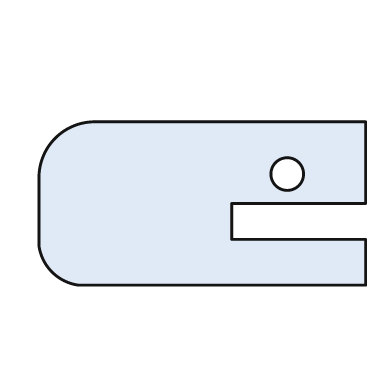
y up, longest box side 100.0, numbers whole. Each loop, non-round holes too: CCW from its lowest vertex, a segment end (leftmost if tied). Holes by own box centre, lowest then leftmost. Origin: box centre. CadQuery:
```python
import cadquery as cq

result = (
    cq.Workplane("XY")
    .moveTo(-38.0, -25.0)
    .lineTo(50.0, -25.0)
    .lineTo(50.0, -11.0)
    .lineTo(9.0, -11.0)
    .lineTo(9.0, 0.0)
    .lineTo(50.0, 0.0)
    .lineTo(50.0, 25.0)
    .lineTo(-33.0, 25.0)
    .threePointArc((-45.0, 20.0), (-50.0, 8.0))
    .lineTo(-50.0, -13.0)
    .threePointArc((-46.0, -21.0), (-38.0, -25.0))
    .close()
    .moveTo(26.0, 9.0)
    .circle(5.0)
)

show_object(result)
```